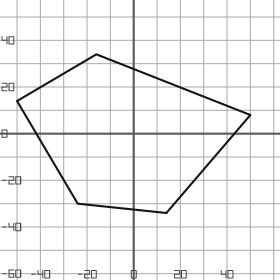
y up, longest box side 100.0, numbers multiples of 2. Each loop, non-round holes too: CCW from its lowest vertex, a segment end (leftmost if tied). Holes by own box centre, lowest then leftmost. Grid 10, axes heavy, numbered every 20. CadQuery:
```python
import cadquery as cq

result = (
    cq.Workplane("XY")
    .moveTo(14.0, -34.0)
    .lineTo(50.0, 8.0)
    .lineTo(-16.0, 34.0)
    .lineTo(-50.0, 14.0)
    .lineTo(-24.0, -30.0)
    .close()
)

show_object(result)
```